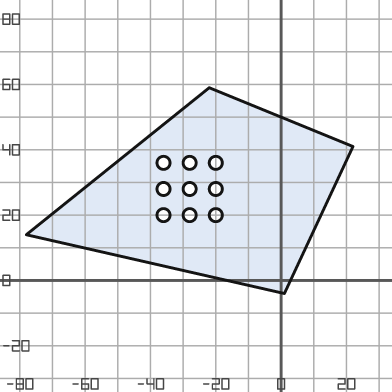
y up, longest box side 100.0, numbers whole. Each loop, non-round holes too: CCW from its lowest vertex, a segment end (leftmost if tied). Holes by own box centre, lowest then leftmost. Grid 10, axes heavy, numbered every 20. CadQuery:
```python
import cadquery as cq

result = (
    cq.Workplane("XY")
    .moveTo(1.0, -4.0)
    .lineTo(22.0, 41.0)
    .lineTo(-22.0, 59.0)
    .lineTo(-78.0, 14.0)
    .close()
    .moveTo(-36.0, 20.0)
    .circle(2.0)
    .moveTo(-28.0, 20.0)
    .circle(2.0)
    .moveTo(-20.0, 20.0)
    .circle(2.0)
    .moveTo(-36.0, 28.0)
    .circle(2.0)
    .moveTo(-28.0, 28.0)
    .circle(2.0)
    .moveTo(-20.0, 28.0)
    .circle(2.0)
    .moveTo(-36.0, 36.0)
    .circle(2.0)
    .moveTo(-28.0, 36.0)
    .circle(2.0)
    .moveTo(-20.0, 36.0)
    .circle(2.0)
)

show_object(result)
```